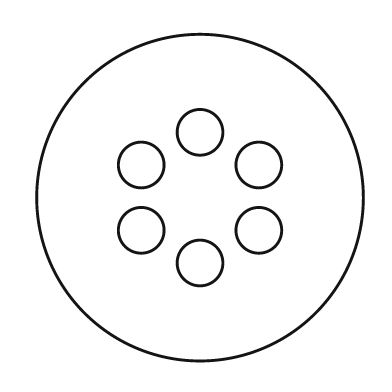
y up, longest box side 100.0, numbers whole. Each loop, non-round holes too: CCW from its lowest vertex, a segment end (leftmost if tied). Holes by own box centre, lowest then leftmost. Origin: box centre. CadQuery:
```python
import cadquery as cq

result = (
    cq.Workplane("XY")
    .moveTo(0.0, 0.0)
    .circle(50.0)
    .moveTo(0.0, -20.0)
    .circle(7.0)
    .moveTo(-18.0, -10.0)
    .circle(7.0)
    .moveTo(18.0, -10.0)
    .circle(7.0)
    .moveTo(-18.0, 10.0)
    .circle(7.0)
    .moveTo(18.0, 10.0)
    .circle(7.0)
    .moveTo(0.0, 20.0)
    .circle(7.0)
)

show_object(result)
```